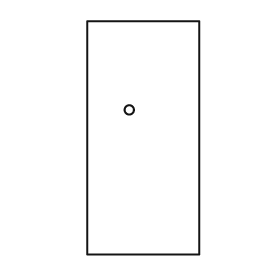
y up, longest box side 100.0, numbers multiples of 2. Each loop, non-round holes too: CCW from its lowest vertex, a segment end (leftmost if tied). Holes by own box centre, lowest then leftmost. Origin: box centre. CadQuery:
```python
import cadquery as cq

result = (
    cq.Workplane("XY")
    .moveTo(-24.0, -50.0)
    .lineTo(24.0, -50.0)
    .lineTo(24.0, 50.0)
    .lineTo(-24.0, 50.0)
    .close()
    .moveTo(-6.0, 12.0)
    .circle(2.0)
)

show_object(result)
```